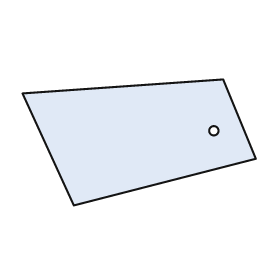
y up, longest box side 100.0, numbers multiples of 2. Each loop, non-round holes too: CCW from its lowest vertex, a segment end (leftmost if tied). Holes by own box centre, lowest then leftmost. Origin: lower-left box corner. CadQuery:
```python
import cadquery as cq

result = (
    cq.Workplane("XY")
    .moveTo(22.0, 0.0)
    .lineTo(100.0, 20.0)
    .lineTo(86.0, 54.0)
    .lineTo(0.0, 48.0)
    .close()
    .moveTo(82.0, 32.0)
    .circle(2.0)
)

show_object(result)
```